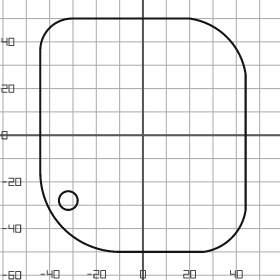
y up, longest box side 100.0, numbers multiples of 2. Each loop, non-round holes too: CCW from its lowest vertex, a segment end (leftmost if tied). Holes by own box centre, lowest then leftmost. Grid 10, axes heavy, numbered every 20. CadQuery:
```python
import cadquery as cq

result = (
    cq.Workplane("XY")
    .moveTo(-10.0, -50.0)
    .lineTo(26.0, -50.0)
    .threePointArc((38.0, -44.0), (44.0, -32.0))
    .lineTo(44.0, 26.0)
    .threePointArc((36.0, 42.0), (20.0, 50.0))
    .lineTo(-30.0, 50.0)
    .threePointArc((-40.0, 46.0), (-44.0, 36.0))
    .lineTo(-44.0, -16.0)
    .threePointArc((-34.0, -40.0), (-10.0, -50.0))
    .close()
    .moveTo(-32.0, -28.0)
    .circle(4.0)
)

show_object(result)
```